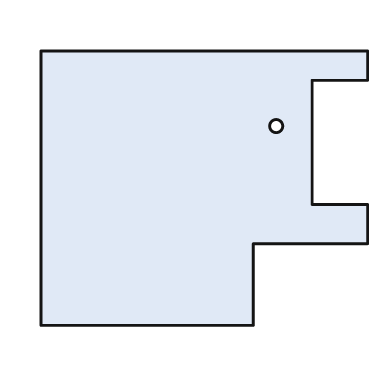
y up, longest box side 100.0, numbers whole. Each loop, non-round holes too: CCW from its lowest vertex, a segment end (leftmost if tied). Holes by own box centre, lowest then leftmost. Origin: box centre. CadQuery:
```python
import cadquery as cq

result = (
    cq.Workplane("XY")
    .moveTo(-50.0, -42.0)
    .lineTo(15.0, -42.0)
    .lineTo(15.0, -17.0)
    .lineTo(50.0, -17.0)
    .lineTo(50.0, -5.0)
    .lineTo(33.0, -5.0)
    .lineTo(33.0, 33.0)
    .lineTo(50.0, 33.0)
    .lineTo(50.0, 42.0)
    .lineTo(-50.0, 42.0)
    .close()
    .moveTo(22.0, 19.0)
    .circle(2.0)
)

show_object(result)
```